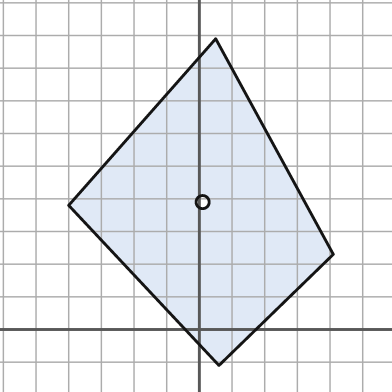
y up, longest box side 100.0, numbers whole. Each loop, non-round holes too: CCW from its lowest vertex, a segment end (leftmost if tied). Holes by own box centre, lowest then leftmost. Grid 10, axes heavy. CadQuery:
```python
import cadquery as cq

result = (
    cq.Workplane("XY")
    .moveTo(6.0, -11.0)
    .lineTo(41.0, 23.0)
    .lineTo(5.0, 89.0)
    .lineTo(-40.0, 38.0)
    .close()
    .moveTo(1.0, 39.0)
    .circle(2.0)
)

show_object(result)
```